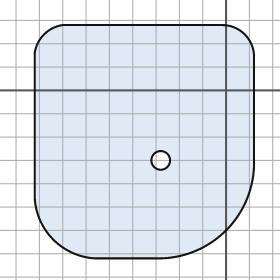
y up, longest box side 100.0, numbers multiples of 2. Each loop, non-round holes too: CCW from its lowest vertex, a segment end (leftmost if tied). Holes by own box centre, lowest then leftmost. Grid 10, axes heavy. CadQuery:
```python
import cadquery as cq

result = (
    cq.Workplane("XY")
    .moveTo(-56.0, -72.0)
    .lineTo(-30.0, -72.0)
    .threePointArc((0.0, -60.0), (12.0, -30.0))
    .lineTo(12.0, 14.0)
    .threePointArc((8.0, 24.0), (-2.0, 28.0))
    .lineTo(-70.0, 28.0)
    .threePointArc((-78.0, 24.0), (-82.0, 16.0))
    .lineTo(-82.0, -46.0)
    .threePointArc((-74.0, -64.0), (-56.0, -72.0))
    .close()
    .moveTo(-28.0, -30.0)
    .circle(4.0)
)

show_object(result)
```